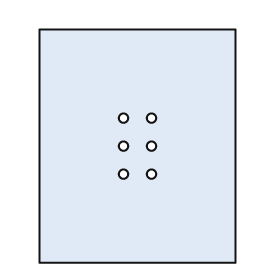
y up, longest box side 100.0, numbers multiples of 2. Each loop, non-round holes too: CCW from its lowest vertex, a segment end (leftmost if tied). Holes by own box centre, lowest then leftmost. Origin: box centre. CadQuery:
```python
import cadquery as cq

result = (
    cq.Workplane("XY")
    .moveTo(-42.0, -50.0)
    .lineTo(42.0, -50.0)
    .lineTo(42.0, 50.0)
    .lineTo(-42.0, 50.0)
    .close()
    .moveTo(-6.0, -12.0)
    .circle(2.0)
    .moveTo(6.0, -12.0)
    .circle(2.0)
    .moveTo(-6.0, 0.0)
    .circle(2.0)
    .moveTo(6.0, 0.0)
    .circle(2.0)
    .moveTo(-6.0, 12.0)
    .circle(2.0)
    .moveTo(6.0, 12.0)
    .circle(2.0)
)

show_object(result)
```